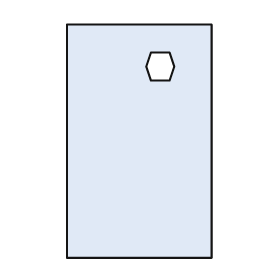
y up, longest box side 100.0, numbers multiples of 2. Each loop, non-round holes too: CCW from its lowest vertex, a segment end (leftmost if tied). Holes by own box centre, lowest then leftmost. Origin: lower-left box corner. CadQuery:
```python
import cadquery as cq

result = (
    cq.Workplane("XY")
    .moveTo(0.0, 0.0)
    .lineTo(62.0, 0.0)
    .lineTo(62.0, 100.0)
    .lineTo(0.0, 100.0)
    .close()
    .moveTo(36.0, 76.0)
    .lineTo(44.0, 76.0)
    .lineTo(46.0, 82.0)
    .lineTo(44.0, 88.0)
    .lineTo(36.0, 88.0)
    .lineTo(34.0, 82.0)
    .close()
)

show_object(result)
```